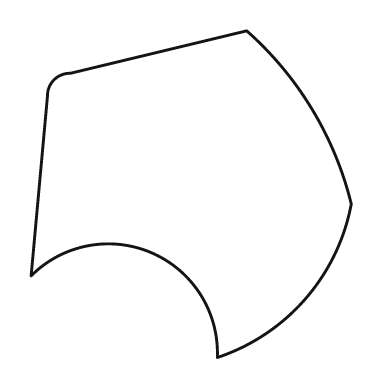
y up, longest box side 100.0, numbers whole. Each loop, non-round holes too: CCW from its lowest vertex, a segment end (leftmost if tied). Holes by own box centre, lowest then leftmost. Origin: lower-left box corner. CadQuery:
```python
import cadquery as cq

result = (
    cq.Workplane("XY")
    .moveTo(57.0, 0.0)
    .threePointArc((84.0, 18.0), (98.0, 47.0))
    .threePointArc((86.0, 76.0), (66.0, 100.0))
    .lineTo(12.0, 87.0)
    .threePointArc((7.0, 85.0), (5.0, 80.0))
    .lineTo(0.0, 25.0)
    .threePointArc((37.0, 32.0), (57.0, 0.0))
    .close()
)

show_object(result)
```